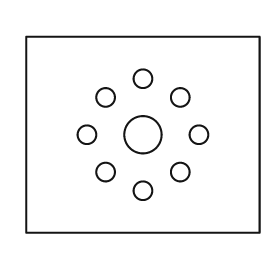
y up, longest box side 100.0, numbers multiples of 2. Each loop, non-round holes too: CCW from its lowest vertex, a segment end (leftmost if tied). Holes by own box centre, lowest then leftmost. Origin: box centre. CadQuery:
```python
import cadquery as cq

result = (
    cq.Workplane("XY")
    .moveTo(-50.0, -42.0)
    .lineTo(50.0, -42.0)
    .lineTo(50.0, 42.0)
    .lineTo(-50.0, 42.0)
    .close()
    .moveTo(0.0, -24.0)
    .circle(4.0)
    .moveTo(-16.0, -16.0)
    .circle(4.0)
    .moveTo(16.0, -16.0)
    .circle(4.0)
    .moveTo(-24.0, 0.0)
    .circle(4.0)
    .moveTo(0.0, 0.0)
    .circle(8.0)
    .moveTo(24.0, 0.0)
    .circle(4.0)
    .moveTo(-16.0, 16.0)
    .circle(4.0)
    .moveTo(16.0, 16.0)
    .circle(4.0)
    .moveTo(0.0, 24.0)
    .circle(4.0)
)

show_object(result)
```